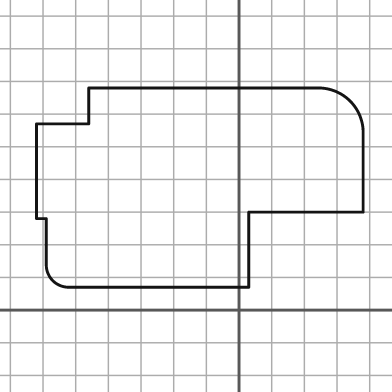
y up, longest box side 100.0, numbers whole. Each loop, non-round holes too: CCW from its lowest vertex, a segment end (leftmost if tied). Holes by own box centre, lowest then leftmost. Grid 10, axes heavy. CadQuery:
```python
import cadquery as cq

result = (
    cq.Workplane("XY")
    .moveTo(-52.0, 7.0)
    .lineTo(3.0, 7.0)
    .lineTo(3.0, 30.0)
    .lineTo(38.0, 30.0)
    .lineTo(38.0, 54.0)
    .threePointArc((34.0, 64.0), (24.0, 68.0))
    .lineTo(-46.0, 68.0)
    .lineTo(-46.0, 57.0)
    .lineTo(-62.0, 57.0)
    .lineTo(-62.0, 28.0)
    .lineTo(-59.0, 28.0)
    .lineTo(-59.0, 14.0)
    .threePointArc((-57.0, 9.0), (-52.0, 7.0))
    .close()
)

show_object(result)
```